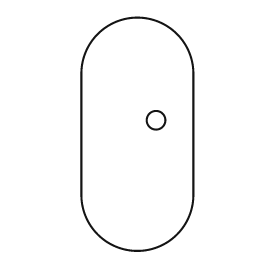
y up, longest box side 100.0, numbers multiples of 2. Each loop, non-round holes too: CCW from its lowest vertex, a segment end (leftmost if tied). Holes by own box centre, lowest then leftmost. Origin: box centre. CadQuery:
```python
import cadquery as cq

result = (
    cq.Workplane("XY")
    .moveTo(-24.0, -26.0)
    .threePointArc((0.0, -50.0), (24.0, -26.0))
    .lineTo(24.0, 26.0)
    .threePointArc((0.0, 50.0), (-24.0, 26.0))
    .close()
    .moveTo(8.0, 6.0)
    .circle(4.0)
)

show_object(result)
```